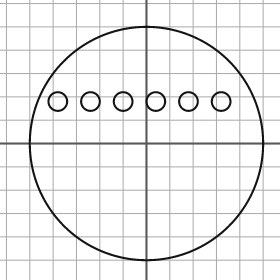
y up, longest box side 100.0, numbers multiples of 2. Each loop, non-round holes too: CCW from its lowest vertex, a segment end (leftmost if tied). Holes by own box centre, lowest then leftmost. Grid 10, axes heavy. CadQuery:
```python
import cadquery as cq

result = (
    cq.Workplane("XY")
    .moveTo(0.0, 0.0)
    .circle(50.0)
    .moveTo(-38.0, 18.0)
    .circle(4.0)
    .moveTo(-24.0, 18.0)
    .circle(4.0)
    .moveTo(-10.0, 18.0)
    .circle(4.0)
    .moveTo(4.0, 18.0)
    .circle(4.0)
    .moveTo(18.0, 18.0)
    .circle(4.0)
    .moveTo(32.0, 18.0)
    .circle(4.0)
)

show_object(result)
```